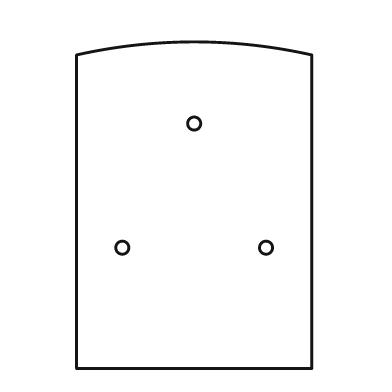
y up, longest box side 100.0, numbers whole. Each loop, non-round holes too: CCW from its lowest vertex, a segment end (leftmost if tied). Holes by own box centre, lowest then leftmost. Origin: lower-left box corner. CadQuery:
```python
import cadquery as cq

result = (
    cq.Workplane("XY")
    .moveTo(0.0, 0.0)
    .lineTo(72.0, 0.0)
    .lineTo(72.0, 96.0)
    .threePointArc((36.0, 100.0), (0.0, 96.0))
    .close()
    .moveTo(14.0, 37.0)
    .circle(2.0)
    .moveTo(58.0, 37.0)
    .circle(2.0)
    .moveTo(36.0, 75.0)
    .circle(2.0)
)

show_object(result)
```